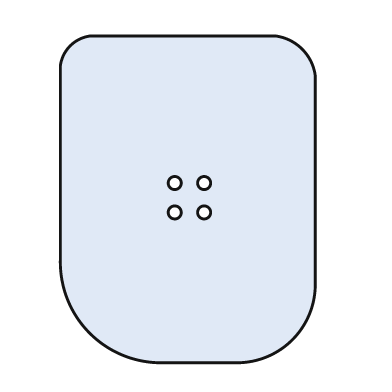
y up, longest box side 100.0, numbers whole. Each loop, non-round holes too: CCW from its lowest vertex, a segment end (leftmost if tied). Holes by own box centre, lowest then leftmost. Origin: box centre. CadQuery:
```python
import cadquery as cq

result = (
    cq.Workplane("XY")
    .moveTo(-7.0, -50.0)
    .lineTo(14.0, -50.0)
    .threePointArc((32.0, -43.0), (39.0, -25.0))
    .lineTo(39.0, 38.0)
    .threePointArc((35.0, 46.0), (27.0, 50.0))
    .lineTo(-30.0, 50.0)
    .threePointArc((-36.0, 47.0), (-39.0, 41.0))
    .lineTo(-39.0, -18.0)
    .threePointArc((-30.0, -41.0), (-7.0, -50.0))
    .close()
    .moveTo(-4.0, -4.0)
    .circle(2.0)
    .moveTo(5.0, -4.0)
    .circle(2.0)
    .moveTo(-4.0, 5.0)
    .circle(2.0)
    .moveTo(5.0, 5.0)
    .circle(2.0)
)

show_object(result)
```